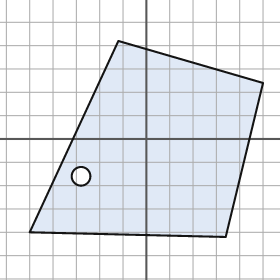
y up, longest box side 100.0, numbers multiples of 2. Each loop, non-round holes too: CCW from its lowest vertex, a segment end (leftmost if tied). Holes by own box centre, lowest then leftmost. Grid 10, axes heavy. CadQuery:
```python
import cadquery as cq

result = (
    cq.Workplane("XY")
    .moveTo(34.0, -42.0)
    .lineTo(50.0, 24.0)
    .lineTo(-12.0, 42.0)
    .lineTo(-50.0, -40.0)
    .close()
    .moveTo(-28.0, -16.0)
    .circle(4.0)
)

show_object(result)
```